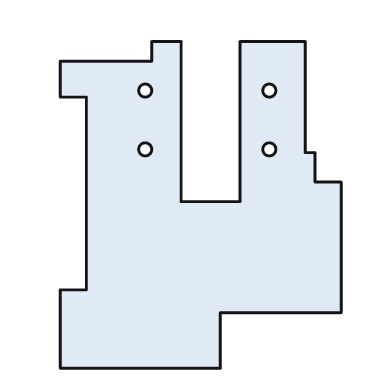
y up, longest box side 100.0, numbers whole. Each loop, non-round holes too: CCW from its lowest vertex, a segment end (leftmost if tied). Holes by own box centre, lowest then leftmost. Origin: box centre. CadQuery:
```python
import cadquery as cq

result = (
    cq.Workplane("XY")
    .moveTo(-43.0, -50.0)
    .lineTo(6.0, -50.0)
    .lineTo(6.0, -33.0)
    .lineTo(43.0, -33.0)
    .lineTo(43.0, 7.0)
    .lineTo(35.0, 7.0)
    .lineTo(35.0, 16.0)
    .lineTo(32.0, 16.0)
    .lineTo(32.0, 50.0)
    .lineTo(12.0, 50.0)
    .lineTo(12.0, 1.0)
    .lineTo(-6.0, 1.0)
    .lineTo(-6.0, 50.0)
    .lineTo(-15.0, 50.0)
    .lineTo(-15.0, 44.0)
    .lineTo(-43.0, 44.0)
    .lineTo(-43.0, 33.0)
    .lineTo(-35.0, 33.0)
    .lineTo(-35.0, -26.0)
    .lineTo(-43.0, -26.0)
    .close()
    .moveTo(-17.0, 17.0)
    .circle(2.0)
    .moveTo(21.0, 17.0)
    .circle(2.0)
    .moveTo(-17.0, 35.0)
    .circle(2.0)
    .moveTo(21.0, 35.0)
    .circle(2.0)
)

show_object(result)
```